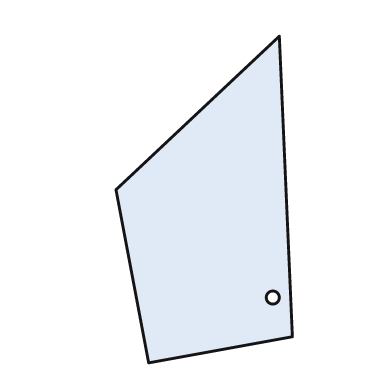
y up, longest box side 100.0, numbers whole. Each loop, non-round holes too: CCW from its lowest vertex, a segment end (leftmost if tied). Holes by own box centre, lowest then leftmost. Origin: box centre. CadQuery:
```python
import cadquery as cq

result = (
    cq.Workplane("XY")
    .moveTo(-17.0, -50.0)
    .lineTo(27.0, -42.0)
    .lineTo(23.0, 50.0)
    .lineTo(-27.0, 3.0)
    .close()
    .moveTo(21.0, -30.0)
    .circle(2.0)
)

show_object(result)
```